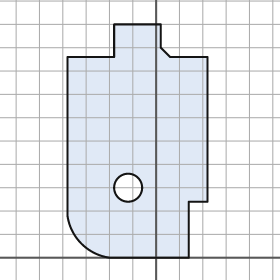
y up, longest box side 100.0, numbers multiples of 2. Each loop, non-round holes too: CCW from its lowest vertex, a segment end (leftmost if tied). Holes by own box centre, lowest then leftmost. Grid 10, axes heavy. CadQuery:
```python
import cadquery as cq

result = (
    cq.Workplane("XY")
    .moveTo(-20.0, 0.0)
    .lineTo(14.0, 0.0)
    .lineTo(14.0, 24.0)
    .lineTo(22.0, 24.0)
    .lineTo(22.0, 86.0)
    .lineTo(6.0, 86.0)
    .lineTo(2.0, 90.0)
    .lineTo(2.0, 100.0)
    .lineTo(-18.0, 100.0)
    .lineTo(-18.0, 86.0)
    .lineTo(-38.0, 86.0)
    .lineTo(-38.0, 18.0)
    .threePointArc((-32.0, 6.0), (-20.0, 0.0))
    .close()
    .moveTo(-12.0, 30.0)
    .circle(6.0)
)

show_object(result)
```